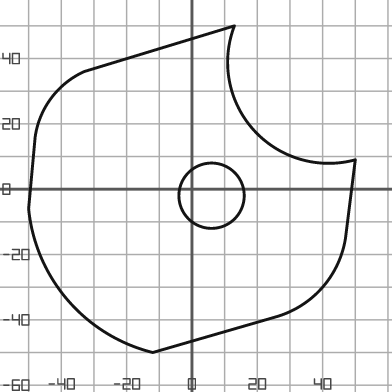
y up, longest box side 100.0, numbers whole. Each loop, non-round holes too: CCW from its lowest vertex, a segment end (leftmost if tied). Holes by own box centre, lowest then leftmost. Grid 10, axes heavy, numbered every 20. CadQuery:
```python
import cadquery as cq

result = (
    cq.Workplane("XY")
    .moveTo(-12.0, -50.0)
    .lineTo(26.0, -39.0)
    .threePointArc((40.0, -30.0), (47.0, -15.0))
    .lineTo(50.0, 9.0)
    .threePointArc((19.0, 18.0), (13.0, 50.0))
    .lineTo(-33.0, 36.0)
    .threePointArc((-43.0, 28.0), (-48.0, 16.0))
    .lineTo(-50.0, -6.0)
    .threePointArc((-38.0, -34.0), (-12.0, -50.0))
    .close()
    .moveTo(6.0, -2.0)
    .circle(10.0)
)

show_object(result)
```